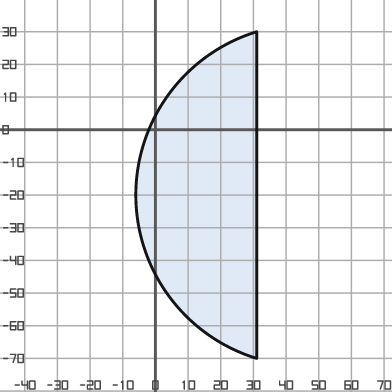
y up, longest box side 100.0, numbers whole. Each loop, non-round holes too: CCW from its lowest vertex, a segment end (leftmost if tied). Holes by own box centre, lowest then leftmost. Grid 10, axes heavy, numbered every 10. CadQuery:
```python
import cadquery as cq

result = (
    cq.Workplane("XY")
    .moveTo(31.0, -70.0)
    .lineTo(31.0, 30.0)
    .threePointArc((-6.0, -20.0), (31.0, -70.0))
    .close()
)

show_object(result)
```